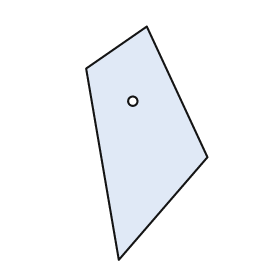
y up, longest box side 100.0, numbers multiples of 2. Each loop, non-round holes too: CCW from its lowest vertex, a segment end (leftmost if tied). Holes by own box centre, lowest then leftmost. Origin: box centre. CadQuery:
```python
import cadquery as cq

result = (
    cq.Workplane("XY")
    .moveTo(-12.0, -50.0)
    .lineTo(26.0, -6.0)
    .lineTo(0.0, 50.0)
    .lineTo(-26.0, 32.0)
    .close()
    .moveTo(-6.0, 18.0)
    .circle(2.0)
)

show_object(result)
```